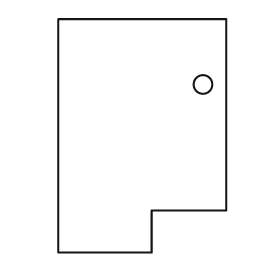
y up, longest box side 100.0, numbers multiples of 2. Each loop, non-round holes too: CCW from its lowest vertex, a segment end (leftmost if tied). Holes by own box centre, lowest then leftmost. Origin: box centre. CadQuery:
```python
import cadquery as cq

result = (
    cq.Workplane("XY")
    .moveTo(-36.0, -50.0)
    .lineTo(4.0, -50.0)
    .lineTo(4.0, -32.0)
    .lineTo(36.0, -32.0)
    .lineTo(36.0, 50.0)
    .lineTo(-36.0, 50.0)
    .close()
    .moveTo(26.0, 22.0)
    .circle(4.0)
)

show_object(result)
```